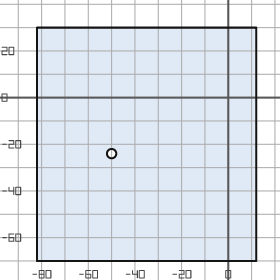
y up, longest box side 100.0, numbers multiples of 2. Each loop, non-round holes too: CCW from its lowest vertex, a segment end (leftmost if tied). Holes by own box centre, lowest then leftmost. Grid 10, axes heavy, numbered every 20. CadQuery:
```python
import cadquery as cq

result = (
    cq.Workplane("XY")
    .moveTo(-82.0, -70.0)
    .lineTo(12.0, -70.0)
    .lineTo(12.0, 30.0)
    .lineTo(-82.0, 30.0)
    .close()
    .moveTo(-50.0, -24.0)
    .circle(2.0)
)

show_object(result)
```